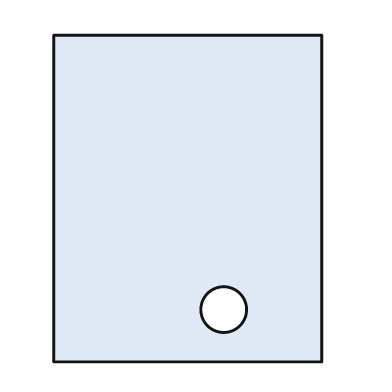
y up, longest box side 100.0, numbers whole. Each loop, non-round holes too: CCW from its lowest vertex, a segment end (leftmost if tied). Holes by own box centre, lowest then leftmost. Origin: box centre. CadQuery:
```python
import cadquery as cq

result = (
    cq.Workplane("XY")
    .moveTo(-41.0, -50.0)
    .lineTo(41.0, -50.0)
    .lineTo(41.0, 50.0)
    .lineTo(-41.0, 50.0)
    .close()
    .moveTo(11.0, -34.0)
    .circle(7.0)
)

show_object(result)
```